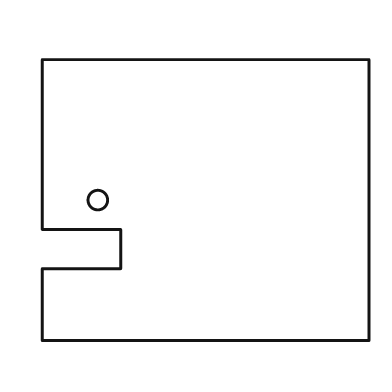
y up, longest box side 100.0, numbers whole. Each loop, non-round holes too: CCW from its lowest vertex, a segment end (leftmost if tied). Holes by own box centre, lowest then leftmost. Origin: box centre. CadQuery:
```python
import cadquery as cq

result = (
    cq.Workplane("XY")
    .moveTo(-50.0, -43.0)
    .lineTo(50.0, -43.0)
    .lineTo(50.0, 43.0)
    .lineTo(-50.0, 43.0)
    .lineTo(-50.0, -9.0)
    .lineTo(-26.0, -9.0)
    .lineTo(-26.0, -21.0)
    .lineTo(-50.0, -21.0)
    .close()
    .moveTo(-33.0, 0.0)
    .circle(3.0)
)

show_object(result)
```